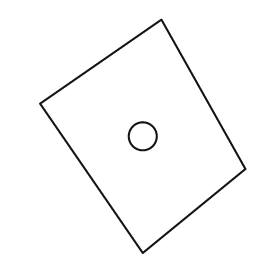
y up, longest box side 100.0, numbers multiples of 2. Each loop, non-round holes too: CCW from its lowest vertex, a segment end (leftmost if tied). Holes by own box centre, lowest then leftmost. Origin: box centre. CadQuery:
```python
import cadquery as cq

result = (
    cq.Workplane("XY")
    .moveTo(0.0, -50.0)
    .lineTo(44.0, -14.0)
    .lineTo(8.0, 50.0)
    .lineTo(-44.0, 14.0)
    .close()
    .moveTo(0.0, 0.0)
    .circle(6.0)
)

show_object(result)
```